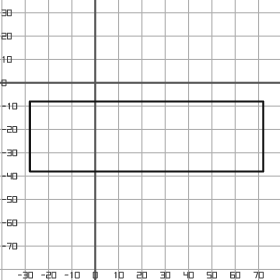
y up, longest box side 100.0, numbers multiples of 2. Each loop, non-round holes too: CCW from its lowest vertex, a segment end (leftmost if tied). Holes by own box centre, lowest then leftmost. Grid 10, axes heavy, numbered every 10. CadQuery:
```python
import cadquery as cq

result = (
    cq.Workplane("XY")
    .moveTo(-28.0, -38.0)
    .lineTo(72.0, -38.0)
    .lineTo(72.0, -8.0)
    .lineTo(-28.0, -8.0)
    .close()
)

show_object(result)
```